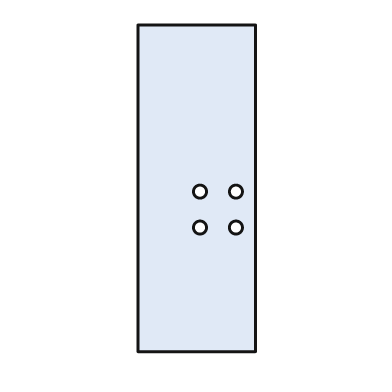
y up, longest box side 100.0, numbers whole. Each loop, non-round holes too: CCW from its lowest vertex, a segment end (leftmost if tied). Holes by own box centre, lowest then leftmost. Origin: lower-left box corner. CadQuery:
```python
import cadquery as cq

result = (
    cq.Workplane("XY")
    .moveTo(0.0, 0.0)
    .lineTo(36.0, 0.0)
    .lineTo(36.0, 100.0)
    .lineTo(0.0, 100.0)
    .close()
    .moveTo(19.0, 38.0)
    .circle(2.0)
    .moveTo(30.0, 38.0)
    .circle(2.0)
    .moveTo(19.0, 49.0)
    .circle(2.0)
    .moveTo(30.0, 49.0)
    .circle(2.0)
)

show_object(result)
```